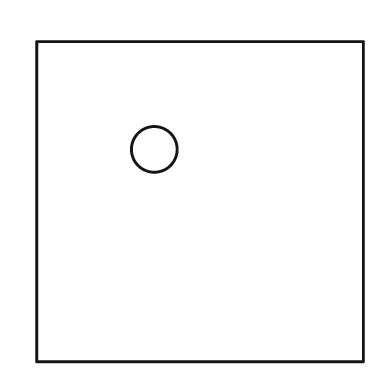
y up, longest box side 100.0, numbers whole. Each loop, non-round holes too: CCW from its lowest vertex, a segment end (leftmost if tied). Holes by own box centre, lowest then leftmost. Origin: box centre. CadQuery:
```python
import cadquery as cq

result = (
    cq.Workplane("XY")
    .moveTo(-50.0, -49.0)
    .lineTo(50.0, -49.0)
    .lineTo(50.0, 49.0)
    .lineTo(-50.0, 49.0)
    .close()
    .moveTo(-14.0, 16.0)
    .circle(7.0)
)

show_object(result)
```